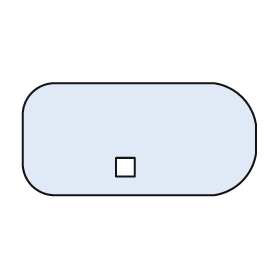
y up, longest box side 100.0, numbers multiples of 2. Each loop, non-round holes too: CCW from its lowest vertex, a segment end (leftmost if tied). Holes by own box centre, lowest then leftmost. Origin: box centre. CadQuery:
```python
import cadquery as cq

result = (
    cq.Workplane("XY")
    .moveTo(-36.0, -24.0)
    .lineTo(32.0, -24.0)
    .threePointArc((44.0, -18.0), (50.0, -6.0))
    .lineTo(50.0, 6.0)
    .threePointArc((44.0, 18.0), (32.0, 24.0))
    .lineTo(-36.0, 24.0)
    .threePointArc((-46.0, 20.0), (-50.0, 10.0))
    .lineTo(-50.0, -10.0)
    .threePointArc((-46.0, -20.0), (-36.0, -24.0))
    .close()
    .moveTo(-10.0, -16.0)
    .lineTo(-2.0, -16.0)
    .lineTo(-2.0, -8.0)
    .lineTo(-10.0, -8.0)
    .close()
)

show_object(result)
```